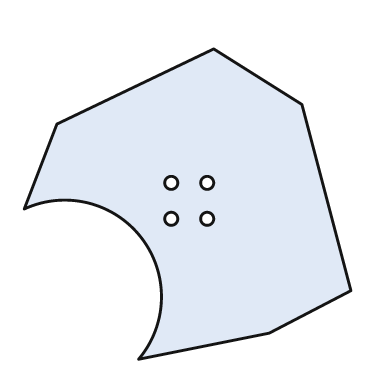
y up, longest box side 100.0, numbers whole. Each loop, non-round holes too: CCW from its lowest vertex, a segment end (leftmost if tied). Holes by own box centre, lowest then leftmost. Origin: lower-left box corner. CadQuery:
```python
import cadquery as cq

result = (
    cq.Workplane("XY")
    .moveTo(35.0, 0.0)
    .lineTo(75.0, 8.0)
    .lineTo(100.0, 21.0)
    .lineTo(85.0, 78.0)
    .lineTo(58.0, 95.0)
    .lineTo(10.0, 72.0)
    .lineTo(0.0, 46.0)
    .threePointArc((36.0, 37.0), (35.0, 0.0))
    .close()
    .moveTo(45.0, 43.0)
    .circle(2.0)
    .moveTo(56.0, 43.0)
    .circle(2.0)
    .moveTo(45.0, 54.0)
    .circle(2.0)
    .moveTo(56.0, 54.0)
    .circle(2.0)
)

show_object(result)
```